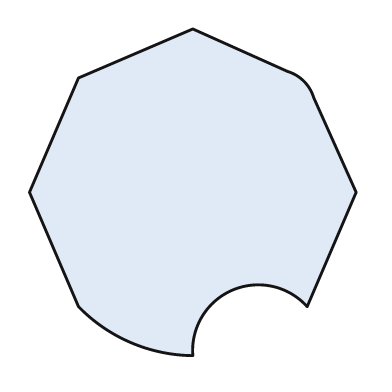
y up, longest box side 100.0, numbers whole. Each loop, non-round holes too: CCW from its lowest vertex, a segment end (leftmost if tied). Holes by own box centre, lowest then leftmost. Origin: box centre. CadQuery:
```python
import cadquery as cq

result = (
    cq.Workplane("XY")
    .moveTo(0.0, -50.0)
    .threePointArc((12.0, -30.0), (35.0, -35.0))
    .lineTo(50.0, 0.0)
    .lineTo(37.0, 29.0)
    .threePointArc((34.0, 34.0), (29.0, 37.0))
    .lineTo(0.0, 50.0)
    .lineTo(-35.0, 35.0)
    .lineTo(-50.0, 0.0)
    .lineTo(-35.0, -35.0)
    .threePointArc((-19.0, -46.0), (0.0, -50.0))
    .close()
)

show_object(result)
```